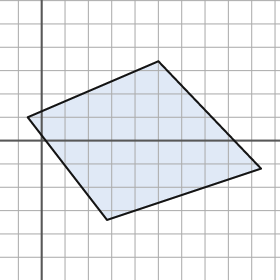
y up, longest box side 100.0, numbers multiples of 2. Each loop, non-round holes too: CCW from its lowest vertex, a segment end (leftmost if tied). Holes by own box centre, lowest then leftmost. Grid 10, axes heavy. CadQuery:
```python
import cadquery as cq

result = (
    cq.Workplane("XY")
    .moveTo(28.0, -34.0)
    .lineTo(94.0, -12.0)
    .lineTo(50.0, 34.0)
    .lineTo(-6.0, 10.0)
    .close()
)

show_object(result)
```